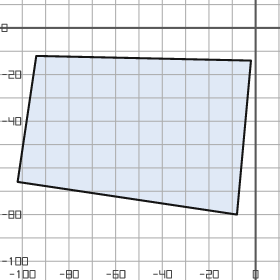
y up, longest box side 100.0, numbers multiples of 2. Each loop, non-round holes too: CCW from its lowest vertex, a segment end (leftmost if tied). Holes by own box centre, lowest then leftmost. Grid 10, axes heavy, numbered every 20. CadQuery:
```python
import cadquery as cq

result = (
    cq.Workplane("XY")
    .moveTo(-8.0, -80.0)
    .lineTo(-2.0, -14.0)
    .lineTo(-94.0, -12.0)
    .lineTo(-102.0, -66.0)
    .close()
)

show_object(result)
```